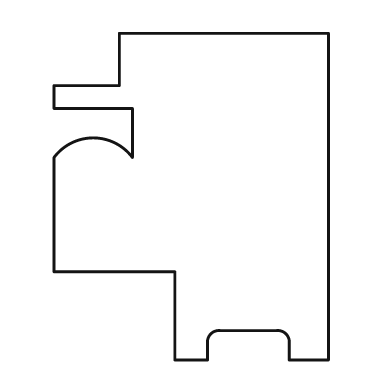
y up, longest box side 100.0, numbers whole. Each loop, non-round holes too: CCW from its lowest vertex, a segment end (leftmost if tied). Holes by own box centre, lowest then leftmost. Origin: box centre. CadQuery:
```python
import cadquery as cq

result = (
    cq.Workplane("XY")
    .moveTo(-5.0, -50.0)
    .lineTo(5.0, -50.0)
    .lineTo(5.0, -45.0)
    .threePointArc((6.0, -42.0), (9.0, -41.0))
    .lineTo(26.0, -41.0)
    .threePointArc((29.0, -42.0), (30.0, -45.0))
    .lineTo(30.0, -50.0)
    .lineTo(42.0, -50.0)
    .lineTo(42.0, 50.0)
    .lineTo(-22.0, 50.0)
    .lineTo(-22.0, 34.0)
    .lineTo(-42.0, 34.0)
    .lineTo(-42.0, 27.0)
    .lineTo(-18.0, 27.0)
    .lineTo(-18.0, 12.0)
    .threePointArc((-30.0, 18.0), (-42.0, 12.0))
    .lineTo(-42.0, -23.0)
    .lineTo(-5.0, -23.0)
    .close()
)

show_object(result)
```